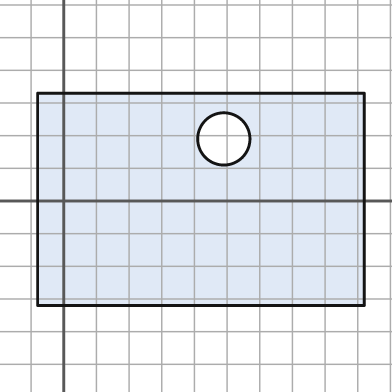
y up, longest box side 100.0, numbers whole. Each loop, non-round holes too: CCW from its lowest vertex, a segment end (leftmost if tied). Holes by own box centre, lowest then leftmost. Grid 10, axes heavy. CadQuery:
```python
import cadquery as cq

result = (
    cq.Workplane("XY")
    .moveTo(-8.0, -32.0)
    .lineTo(92.0, -32.0)
    .lineTo(92.0, 33.0)
    .lineTo(-8.0, 33.0)
    .close()
    .moveTo(49.0, 19.0)
    .circle(8.0)
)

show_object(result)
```